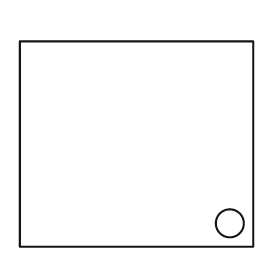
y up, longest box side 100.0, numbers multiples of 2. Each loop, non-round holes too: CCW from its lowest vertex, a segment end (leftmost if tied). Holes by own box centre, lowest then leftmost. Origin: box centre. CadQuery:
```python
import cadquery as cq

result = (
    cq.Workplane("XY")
    .moveTo(-50.0, -44.0)
    .lineTo(50.0, -44.0)
    .lineTo(50.0, 44.0)
    .lineTo(-50.0, 44.0)
    .close()
    .moveTo(40.0, -34.0)
    .circle(6.0)
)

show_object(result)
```